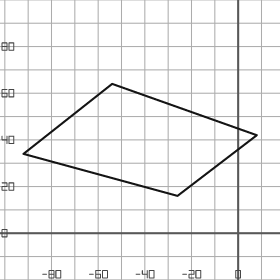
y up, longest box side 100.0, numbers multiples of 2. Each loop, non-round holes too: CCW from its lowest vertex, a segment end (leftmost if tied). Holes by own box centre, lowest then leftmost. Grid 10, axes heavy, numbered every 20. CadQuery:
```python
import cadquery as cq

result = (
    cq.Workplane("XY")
    .moveTo(-26.0, 16.0)
    .lineTo(8.0, 42.0)
    .lineTo(-54.0, 64.0)
    .lineTo(-92.0, 34.0)
    .close()
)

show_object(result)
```